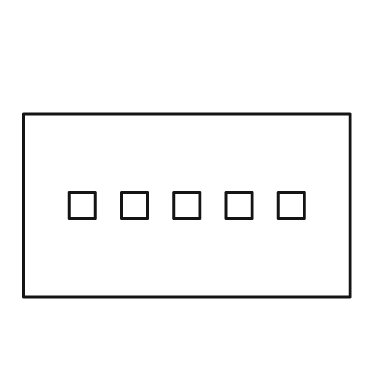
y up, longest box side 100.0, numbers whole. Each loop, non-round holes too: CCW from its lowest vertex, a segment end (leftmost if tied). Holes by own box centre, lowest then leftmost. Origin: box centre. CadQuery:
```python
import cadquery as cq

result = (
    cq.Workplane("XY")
    .moveTo(-50.0, -28.0)
    .lineTo(50.0, -28.0)
    .lineTo(50.0, 28.0)
    .lineTo(-50.0, 28.0)
    .close()
    .moveTo(-36.0, -4.0)
    .lineTo(-28.0, -4.0)
    .lineTo(-28.0, 4.0)
    .lineTo(-36.0, 4.0)
    .close()
    .moveTo(-20.0, -4.0)
    .lineTo(-12.0, -4.0)
    .lineTo(-12.0, 4.0)
    .lineTo(-20.0, 4.0)
    .close()
    .moveTo(-4.0, -4.0)
    .lineTo(4.0, -4.0)
    .lineTo(4.0, 4.0)
    .lineTo(-4.0, 4.0)
    .close()
    .moveTo(12.0, -4.0)
    .lineTo(20.0, -4.0)
    .lineTo(20.0, 4.0)
    .lineTo(12.0, 4.0)
    .close()
    .moveTo(28.0, -4.0)
    .lineTo(36.0, -4.0)
    .lineTo(36.0, 4.0)
    .lineTo(28.0, 4.0)
    .close()
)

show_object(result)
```